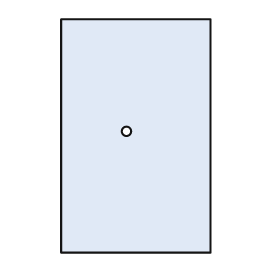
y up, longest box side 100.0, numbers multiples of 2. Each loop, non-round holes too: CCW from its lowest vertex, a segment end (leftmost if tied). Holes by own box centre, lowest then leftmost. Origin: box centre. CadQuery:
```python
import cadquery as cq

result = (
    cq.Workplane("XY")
    .moveTo(-32.0, -50.0)
    .lineTo(32.0, -50.0)
    .lineTo(32.0, 50.0)
    .lineTo(-32.0, 50.0)
    .close()
    .moveTo(-4.0, 2.0)
    .circle(2.0)
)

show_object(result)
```